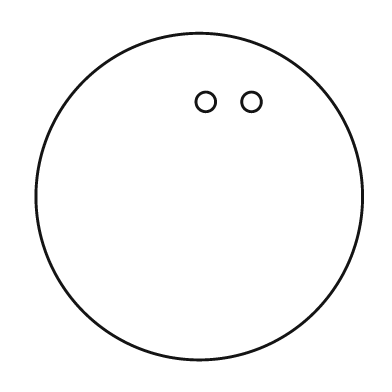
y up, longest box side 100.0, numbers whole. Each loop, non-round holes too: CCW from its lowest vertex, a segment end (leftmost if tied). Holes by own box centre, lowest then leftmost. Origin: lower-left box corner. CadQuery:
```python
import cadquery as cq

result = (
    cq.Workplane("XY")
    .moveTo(50.0, 50.0)
    .circle(50.0)
    .moveTo(52.0, 79.0)
    .circle(3.0)
    .moveTo(66.0, 79.0)
    .circle(3.0)
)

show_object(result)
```